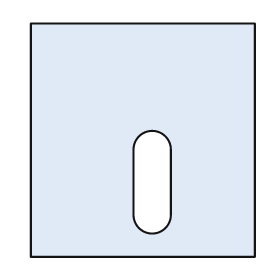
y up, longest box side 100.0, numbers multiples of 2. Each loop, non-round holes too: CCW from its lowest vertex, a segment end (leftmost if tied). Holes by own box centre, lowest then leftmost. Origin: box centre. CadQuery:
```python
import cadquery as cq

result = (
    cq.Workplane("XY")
    .moveTo(-48.0, -50.0)
    .lineTo(48.0, -50.0)
    .lineTo(48.0, 50.0)
    .lineTo(-48.0, 50.0)
    .close()
    .moveTo(-4.0, -32.0)
    .threePointArc((4.0, -40.0), (12.0, -32.0))
    .lineTo(12.0, -4.0)
    .threePointArc((4.0, 4.0), (-4.0, -4.0))
    .close()
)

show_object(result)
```